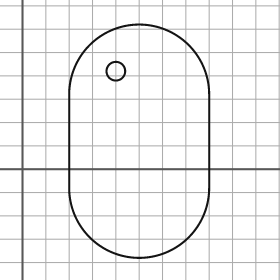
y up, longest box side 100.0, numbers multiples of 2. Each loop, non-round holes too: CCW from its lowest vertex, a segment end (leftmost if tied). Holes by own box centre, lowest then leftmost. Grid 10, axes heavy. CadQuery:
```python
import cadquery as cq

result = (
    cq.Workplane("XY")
    .moveTo(20.0, -8.0)
    .threePointArc((50.0, -38.0), (80.0, -8.0))
    .lineTo(80.0, 32.0)
    .threePointArc((50.0, 62.0), (20.0, 32.0))
    .close()
    .moveTo(40.0, 42.0)
    .circle(4.0)
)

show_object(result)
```